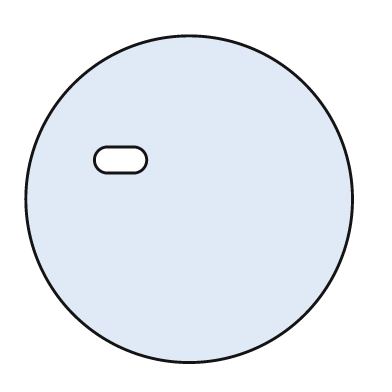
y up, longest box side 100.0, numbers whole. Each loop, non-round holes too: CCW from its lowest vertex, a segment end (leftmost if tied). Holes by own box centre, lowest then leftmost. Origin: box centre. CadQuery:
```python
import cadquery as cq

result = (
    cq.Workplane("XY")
    .moveTo(0.0, 0.0)
    .circle(50.0)
    .moveTo(-25.0, 8.0)
    .lineTo(-17.0, 8.0)
    .threePointArc((-13.0, 12.0), (-17.0, 16.0))
    .lineTo(-25.0, 16.0)
    .threePointArc((-29.0, 12.0), (-25.0, 8.0))
    .close()
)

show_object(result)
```